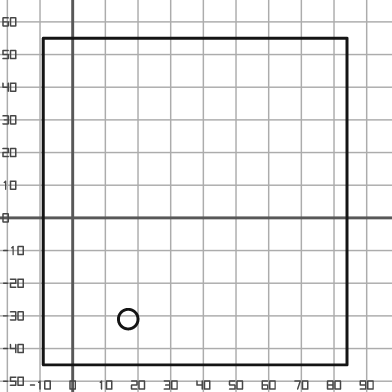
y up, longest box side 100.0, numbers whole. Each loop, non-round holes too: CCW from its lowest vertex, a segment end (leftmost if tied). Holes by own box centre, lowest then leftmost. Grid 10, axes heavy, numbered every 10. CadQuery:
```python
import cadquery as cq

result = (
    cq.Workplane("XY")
    .moveTo(-9.0, -45.0)
    .lineTo(84.0, -45.0)
    .lineTo(84.0, 55.0)
    .lineTo(-9.0, 55.0)
    .close()
    .moveTo(17.0, -31.0)
    .circle(3.0)
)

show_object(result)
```